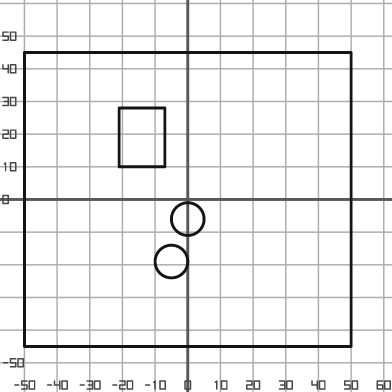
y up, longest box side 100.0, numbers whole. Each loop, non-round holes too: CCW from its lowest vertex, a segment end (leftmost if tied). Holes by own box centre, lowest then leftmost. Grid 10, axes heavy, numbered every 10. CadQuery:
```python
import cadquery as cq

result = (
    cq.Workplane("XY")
    .moveTo(-50.0, -45.0)
    .lineTo(50.0, -45.0)
    .lineTo(50.0, 45.0)
    .lineTo(-50.0, 45.0)
    .close()
    .moveTo(-5.0, -19.0)
    .circle(5.0)
    .moveTo(0.0, -6.0)
    .circle(5.0)
    .moveTo(-21.0, 10.0)
    .lineTo(-7.0, 10.0)
    .lineTo(-7.0, 28.0)
    .lineTo(-21.0, 28.0)
    .close()
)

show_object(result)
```